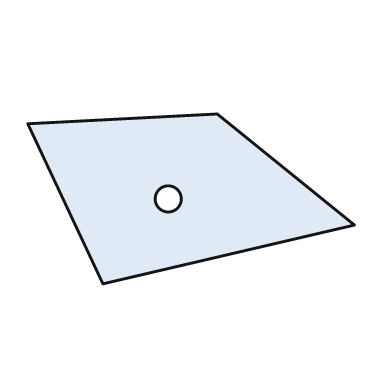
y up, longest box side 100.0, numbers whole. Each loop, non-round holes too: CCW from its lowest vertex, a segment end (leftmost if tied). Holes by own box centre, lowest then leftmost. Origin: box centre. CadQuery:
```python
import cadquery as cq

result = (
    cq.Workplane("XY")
    .moveTo(-27.0, -26.0)
    .lineTo(50.0, -8.0)
    .lineTo(8.0, 26.0)
    .lineTo(-50.0, 23.0)
    .close()
    .moveTo(-7.0, 0.0)
    .circle(4.0)
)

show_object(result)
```